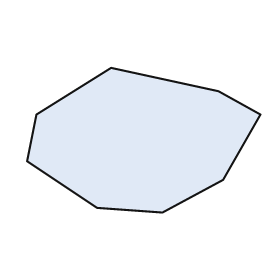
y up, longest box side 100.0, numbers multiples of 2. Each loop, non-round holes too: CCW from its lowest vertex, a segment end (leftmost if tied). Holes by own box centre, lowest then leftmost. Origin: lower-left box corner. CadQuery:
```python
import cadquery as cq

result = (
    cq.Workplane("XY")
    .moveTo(58.0, 0.0)
    .lineTo(84.0, 14.0)
    .lineTo(100.0, 42.0)
    .lineTo(82.0, 52.0)
    .lineTo(36.0, 62.0)
    .lineTo(4.0, 42.0)
    .lineTo(0.0, 22.0)
    .lineTo(30.0, 2.0)
    .close()
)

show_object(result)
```